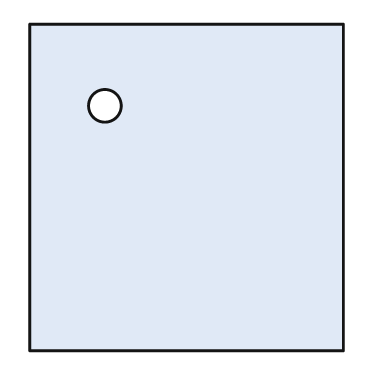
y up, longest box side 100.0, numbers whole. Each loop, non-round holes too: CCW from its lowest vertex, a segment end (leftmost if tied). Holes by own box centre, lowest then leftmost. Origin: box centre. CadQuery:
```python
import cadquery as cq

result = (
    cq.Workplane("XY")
    .moveTo(-48.0, -50.0)
    .lineTo(48.0, -50.0)
    .lineTo(48.0, 50.0)
    .lineTo(-48.0, 50.0)
    .close()
    .moveTo(-25.0, 25.0)
    .circle(5.0)
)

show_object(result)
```